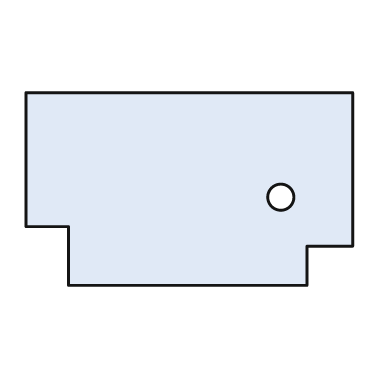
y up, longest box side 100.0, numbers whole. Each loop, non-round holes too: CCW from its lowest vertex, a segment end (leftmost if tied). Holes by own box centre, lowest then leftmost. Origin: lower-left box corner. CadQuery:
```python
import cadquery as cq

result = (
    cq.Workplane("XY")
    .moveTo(13.0, 0.0)
    .lineTo(86.0, 0.0)
    .lineTo(86.0, 12.0)
    .lineTo(100.0, 12.0)
    .lineTo(100.0, 59.0)
    .lineTo(0.0, 59.0)
    .lineTo(0.0, 18.0)
    .lineTo(13.0, 18.0)
    .close()
    .moveTo(78.0, 27.0)
    .circle(4.0)
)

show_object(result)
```